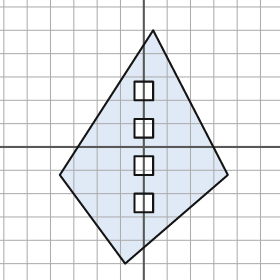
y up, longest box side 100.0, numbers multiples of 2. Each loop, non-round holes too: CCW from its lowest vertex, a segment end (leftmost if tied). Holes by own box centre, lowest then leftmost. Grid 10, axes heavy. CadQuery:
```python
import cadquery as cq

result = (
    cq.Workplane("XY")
    .moveTo(-8.0, -50.0)
    .lineTo(36.0, -12.0)
    .lineTo(4.0, 50.0)
    .lineTo(-36.0, -12.0)
    .close()
    .moveTo(-4.0, -28.0)
    .lineTo(4.0, -28.0)
    .lineTo(4.0, -20.0)
    .lineTo(-4.0, -20.0)
    .close()
    .moveTo(-4.0, -12.0)
    .lineTo(4.0, -12.0)
    .lineTo(4.0, -4.0)
    .lineTo(-4.0, -4.0)
    .close()
    .moveTo(-4.0, 4.0)
    .lineTo(4.0, 4.0)
    .lineTo(4.0, 12.0)
    .lineTo(-4.0, 12.0)
    .close()
    .moveTo(-4.0, 20.0)
    .lineTo(4.0, 20.0)
    .lineTo(4.0, 28.0)
    .lineTo(-4.0, 28.0)
    .close()
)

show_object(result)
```